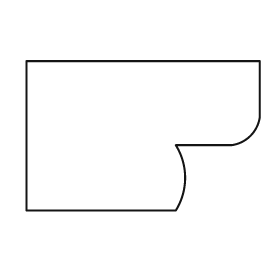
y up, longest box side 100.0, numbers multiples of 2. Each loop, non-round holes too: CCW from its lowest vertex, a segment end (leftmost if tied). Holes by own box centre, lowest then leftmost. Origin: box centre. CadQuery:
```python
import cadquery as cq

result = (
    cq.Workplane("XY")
    .moveTo(-50.0, -32.0)
    .lineTo(14.0, -32.0)
    .threePointArc((18.0, -18.0), (14.0, -4.0))
    .lineTo(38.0, -4.0)
    .threePointArc((46.0, 0.0), (50.0, 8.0))
    .lineTo(50.0, 32.0)
    .lineTo(-50.0, 32.0)
    .close()
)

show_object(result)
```